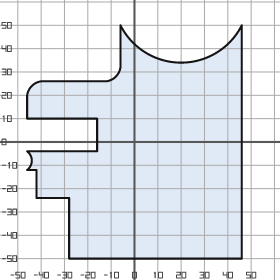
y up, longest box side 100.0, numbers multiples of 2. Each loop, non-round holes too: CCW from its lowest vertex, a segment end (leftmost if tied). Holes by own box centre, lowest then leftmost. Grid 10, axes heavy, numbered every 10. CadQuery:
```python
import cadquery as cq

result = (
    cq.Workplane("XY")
    .moveTo(-28.0, -50.0)
    .lineTo(46.0, -50.0)
    .lineTo(46.0, 50.0)
    .threePointArc((20.0, 34.0), (-6.0, 50.0))
    .lineTo(-6.0, 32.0)
    .threePointArc((-8.0, 28.0), (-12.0, 26.0))
    .lineTo(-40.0, 26.0)
    .threePointArc((-44.0, 24.0), (-46.0, 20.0))
    .lineTo(-46.0, 10.0)
    .lineTo(-16.0, 10.0)
    .lineTo(-16.0, -4.0)
    .lineTo(-46.0, -4.0)
    .threePointArc((-44.0, -8.0), (-46.0, -12.0))
    .lineTo(-42.0, -12.0)
    .lineTo(-42.0, -24.0)
    .lineTo(-28.0, -24.0)
    .close()
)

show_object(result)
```